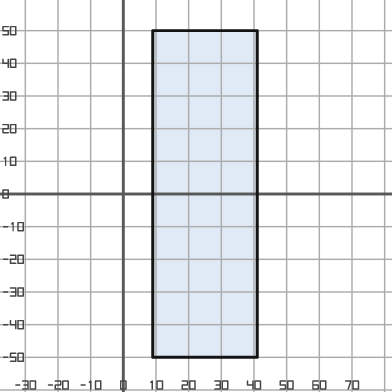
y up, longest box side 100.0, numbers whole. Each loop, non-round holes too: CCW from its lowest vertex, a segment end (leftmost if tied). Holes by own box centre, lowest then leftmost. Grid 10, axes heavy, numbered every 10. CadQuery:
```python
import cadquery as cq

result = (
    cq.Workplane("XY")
    .moveTo(9.0, -50.0)
    .lineTo(41.0, -50.0)
    .lineTo(41.0, 50.0)
    .lineTo(9.0, 50.0)
    .close()
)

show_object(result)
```